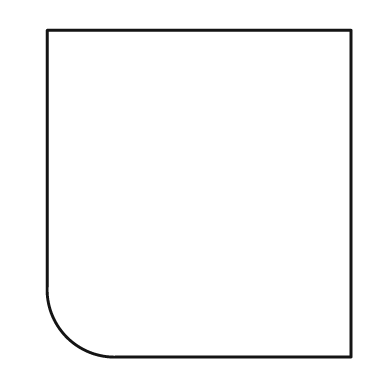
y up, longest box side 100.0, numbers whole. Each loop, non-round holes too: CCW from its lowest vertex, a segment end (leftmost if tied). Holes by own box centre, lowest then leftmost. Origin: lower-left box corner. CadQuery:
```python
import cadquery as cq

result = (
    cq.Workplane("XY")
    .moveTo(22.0, 0.0)
    .lineTo(93.0, 0.0)
    .lineTo(93.0, 100.0)
    .lineTo(0.0, 100.0)
    .lineTo(0.0, 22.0)
    .threePointArc((6.0, 6.0), (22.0, 0.0))
    .close()
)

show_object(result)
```